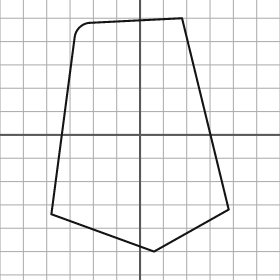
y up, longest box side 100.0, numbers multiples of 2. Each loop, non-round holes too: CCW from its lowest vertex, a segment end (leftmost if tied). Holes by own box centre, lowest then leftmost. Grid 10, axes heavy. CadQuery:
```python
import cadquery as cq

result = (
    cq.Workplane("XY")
    .moveTo(6.0, -50.0)
    .lineTo(38.0, -32.0)
    .lineTo(18.0, 50.0)
    .lineTo(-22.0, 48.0)
    .threePointArc((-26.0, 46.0), (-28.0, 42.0))
    .lineTo(-38.0, -34.0)
    .close()
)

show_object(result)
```